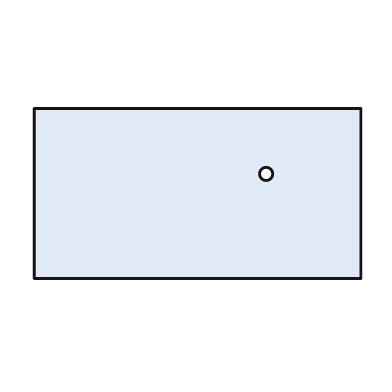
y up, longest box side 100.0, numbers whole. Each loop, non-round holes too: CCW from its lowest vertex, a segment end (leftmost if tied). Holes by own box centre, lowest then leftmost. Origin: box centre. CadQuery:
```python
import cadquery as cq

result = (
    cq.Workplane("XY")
    .moveTo(-50.0, -26.0)
    .lineTo(50.0, -26.0)
    .lineTo(50.0, 26.0)
    .lineTo(-50.0, 26.0)
    .close()
    .moveTo(21.0, 6.0)
    .circle(2.0)
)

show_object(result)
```